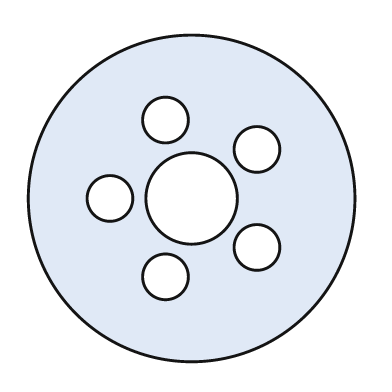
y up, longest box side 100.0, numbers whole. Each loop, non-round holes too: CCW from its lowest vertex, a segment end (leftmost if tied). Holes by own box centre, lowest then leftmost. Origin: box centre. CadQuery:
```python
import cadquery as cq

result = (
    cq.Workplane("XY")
    .moveTo(0.0, 0.0)
    .circle(50.0)
    .moveTo(-8.0, -24.0)
    .circle(7.0)
    .moveTo(20.0, -15.0)
    .circle(7.0)
    .moveTo(-25.0, 0.0)
    .circle(7.0)
    .moveTo(0.0, 0.0)
    .circle(14.0)
    .moveTo(20.0, 15.0)
    .circle(7.0)
    .moveTo(-8.0, 24.0)
    .circle(7.0)
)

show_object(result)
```